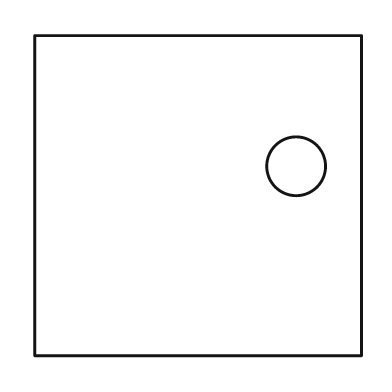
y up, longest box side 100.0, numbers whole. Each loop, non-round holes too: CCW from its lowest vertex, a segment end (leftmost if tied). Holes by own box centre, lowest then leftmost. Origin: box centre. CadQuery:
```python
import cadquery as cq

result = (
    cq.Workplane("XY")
    .moveTo(-50.0, -49.0)
    .lineTo(50.0, -49.0)
    .lineTo(50.0, 49.0)
    .lineTo(-50.0, 49.0)
    .close()
    .moveTo(30.0, 9.0)
    .circle(9.0)
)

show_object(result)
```